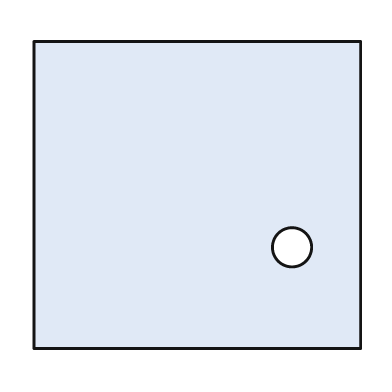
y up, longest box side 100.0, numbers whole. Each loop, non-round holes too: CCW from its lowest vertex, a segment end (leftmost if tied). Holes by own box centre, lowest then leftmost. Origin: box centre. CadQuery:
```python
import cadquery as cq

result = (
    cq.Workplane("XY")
    .moveTo(-50.0, -47.0)
    .lineTo(50.0, -47.0)
    .lineTo(50.0, 47.0)
    .lineTo(-50.0, 47.0)
    .close()
    .moveTo(29.0, -16.0)
    .circle(6.0)
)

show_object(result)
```